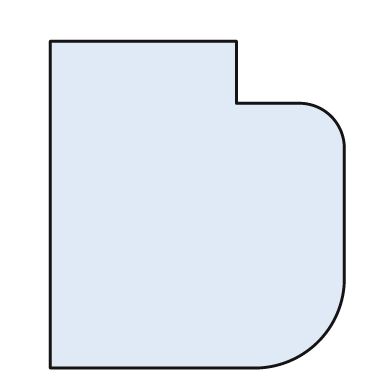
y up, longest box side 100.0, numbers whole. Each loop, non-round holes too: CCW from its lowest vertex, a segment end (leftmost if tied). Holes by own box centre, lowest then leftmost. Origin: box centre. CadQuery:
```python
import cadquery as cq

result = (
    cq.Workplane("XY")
    .moveTo(-45.0, -50.0)
    .lineTo(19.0, -50.0)
    .threePointArc((37.0, -42.0), (45.0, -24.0))
    .lineTo(45.0, 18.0)
    .threePointArc((41.0, 27.0), (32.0, 31.0))
    .lineTo(12.0, 31.0)
    .lineTo(12.0, 50.0)
    .lineTo(-45.0, 50.0)
    .close()
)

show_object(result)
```